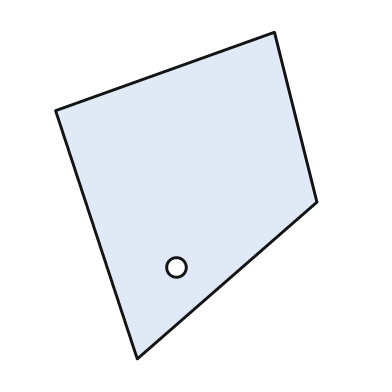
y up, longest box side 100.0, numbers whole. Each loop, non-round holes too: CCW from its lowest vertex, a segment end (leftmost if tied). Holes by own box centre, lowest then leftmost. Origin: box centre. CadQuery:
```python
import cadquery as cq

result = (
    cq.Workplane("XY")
    .moveTo(-15.0, -50.0)
    .lineTo(40.0, -2.0)
    .lineTo(27.0, 50.0)
    .lineTo(-40.0, 26.0)
    .close()
    .moveTo(-3.0, -22.0)
    .circle(3.0)
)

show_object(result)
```